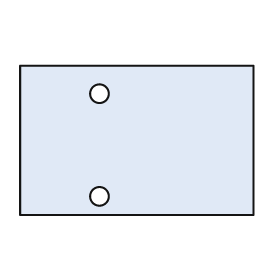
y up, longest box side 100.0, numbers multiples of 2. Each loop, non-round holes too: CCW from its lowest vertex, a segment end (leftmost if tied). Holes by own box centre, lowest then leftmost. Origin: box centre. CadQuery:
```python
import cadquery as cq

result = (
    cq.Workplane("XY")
    .moveTo(-50.0, -32.0)
    .lineTo(50.0, -32.0)
    .lineTo(50.0, 32.0)
    .lineTo(-50.0, 32.0)
    .close()
    .moveTo(-16.0, -24.0)
    .circle(4.0)
    .moveTo(-16.0, 20.0)
    .circle(4.0)
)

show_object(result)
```